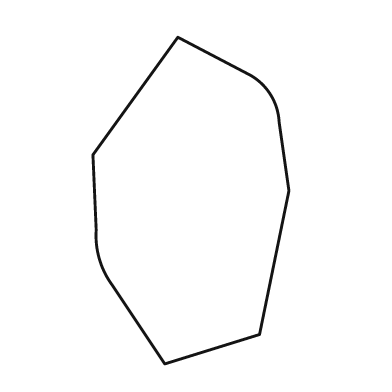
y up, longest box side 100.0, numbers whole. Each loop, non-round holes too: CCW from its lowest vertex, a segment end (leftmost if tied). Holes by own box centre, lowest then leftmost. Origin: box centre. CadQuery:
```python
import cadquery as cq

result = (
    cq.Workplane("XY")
    .moveTo(-8.0, -50.0)
    .lineTo(21.0, -41.0)
    .lineTo(30.0, 3.0)
    .lineTo(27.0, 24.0)
    .threePointArc((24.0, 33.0), (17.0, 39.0))
    .lineTo(-4.0, 50.0)
    .lineTo(-30.0, 14.0)
    .lineTo(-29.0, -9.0)
    .threePointArc((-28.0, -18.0), (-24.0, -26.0))
    .close()
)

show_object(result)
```